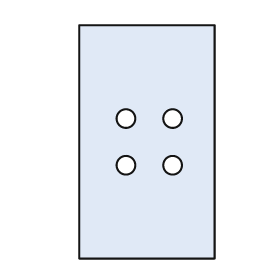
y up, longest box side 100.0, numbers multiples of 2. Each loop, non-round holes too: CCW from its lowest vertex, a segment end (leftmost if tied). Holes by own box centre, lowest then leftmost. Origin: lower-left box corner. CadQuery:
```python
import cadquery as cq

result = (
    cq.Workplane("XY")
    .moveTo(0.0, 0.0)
    .lineTo(58.0, 0.0)
    .lineTo(58.0, 100.0)
    .lineTo(0.0, 100.0)
    .close()
    .moveTo(20.0, 40.0)
    .circle(4.0)
    .moveTo(40.0, 40.0)
    .circle(4.0)
    .moveTo(20.0, 60.0)
    .circle(4.0)
    .moveTo(40.0, 60.0)
    .circle(4.0)
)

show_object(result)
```